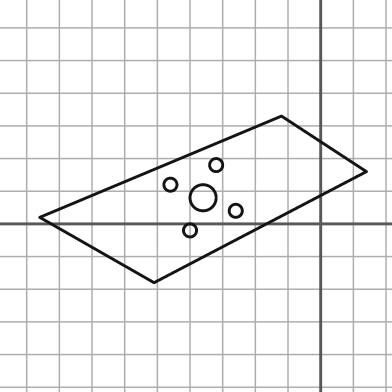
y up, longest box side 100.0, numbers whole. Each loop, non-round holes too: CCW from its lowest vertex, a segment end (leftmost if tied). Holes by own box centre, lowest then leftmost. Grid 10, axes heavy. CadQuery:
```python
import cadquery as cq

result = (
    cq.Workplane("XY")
    .moveTo(-51.0, -18.0)
    .lineTo(14.0, 16.0)
    .lineTo(-12.0, 33.0)
    .lineTo(-86.0, 2.0)
    .close()
    .moveTo(-40.0, -2.0)
    .circle(2.0)
    .moveTo(-26.0, 4.0)
    .circle(2.0)
    .moveTo(-36.0, 8.0)
    .circle(4.0)
    .moveTo(-46.0, 12.0)
    .circle(2.0)
    .moveTo(-32.0, 18.0)
    .circle(2.0)
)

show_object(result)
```